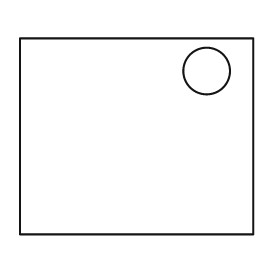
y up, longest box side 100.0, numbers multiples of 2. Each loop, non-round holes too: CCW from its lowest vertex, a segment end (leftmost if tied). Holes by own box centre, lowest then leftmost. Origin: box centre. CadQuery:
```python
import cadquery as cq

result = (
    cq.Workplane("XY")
    .moveTo(-50.0, -42.0)
    .lineTo(50.0, -42.0)
    .lineTo(50.0, 42.0)
    .lineTo(-50.0, 42.0)
    .close()
    .moveTo(30.0, 28.0)
    .circle(10.0)
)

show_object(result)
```